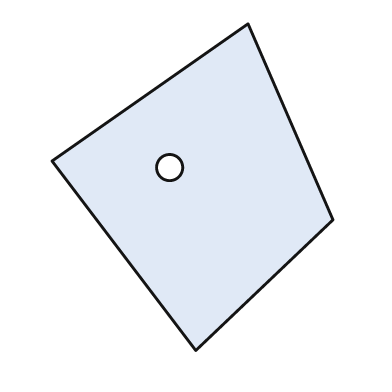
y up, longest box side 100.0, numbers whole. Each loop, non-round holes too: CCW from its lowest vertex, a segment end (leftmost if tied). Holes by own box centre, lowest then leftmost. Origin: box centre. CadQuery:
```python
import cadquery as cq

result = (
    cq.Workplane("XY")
    .moveTo(1.0, -50.0)
    .lineTo(43.0, -10.0)
    .lineTo(17.0, 50.0)
    .lineTo(-43.0, 8.0)
    .close()
    .moveTo(-7.0, 6.0)
    .circle(4.0)
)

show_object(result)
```